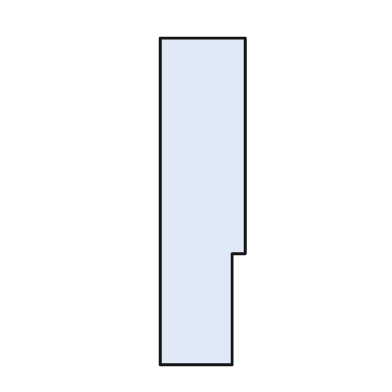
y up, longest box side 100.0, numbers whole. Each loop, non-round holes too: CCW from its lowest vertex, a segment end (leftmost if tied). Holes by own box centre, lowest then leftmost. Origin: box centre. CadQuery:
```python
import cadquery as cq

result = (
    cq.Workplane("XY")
    .moveTo(-13.0, -50.0)
    .lineTo(9.0, -50.0)
    .lineTo(9.0, -16.0)
    .lineTo(13.0, -16.0)
    .lineTo(13.0, 50.0)
    .lineTo(-13.0, 50.0)
    .close()
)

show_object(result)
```